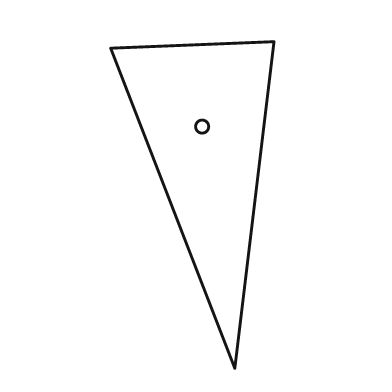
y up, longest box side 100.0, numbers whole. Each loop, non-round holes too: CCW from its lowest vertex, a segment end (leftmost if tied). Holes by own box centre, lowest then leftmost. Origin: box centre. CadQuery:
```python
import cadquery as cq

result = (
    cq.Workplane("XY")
    .moveTo(13.0, -50.0)
    .lineTo(25.0, 50.0)
    .lineTo(-25.0, 48.0)
    .close()
    .moveTo(3.0, 24.0)
    .circle(2.0)
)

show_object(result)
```